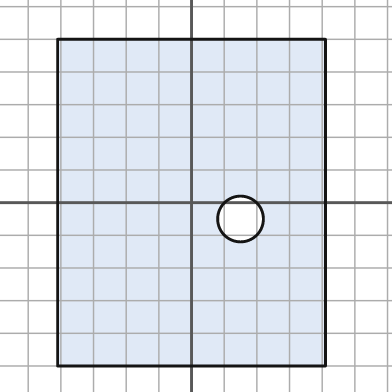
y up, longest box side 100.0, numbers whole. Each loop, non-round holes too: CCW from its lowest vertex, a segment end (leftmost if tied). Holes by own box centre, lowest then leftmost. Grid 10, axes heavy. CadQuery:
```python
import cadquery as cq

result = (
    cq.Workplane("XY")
    .moveTo(-41.0, -50.0)
    .lineTo(41.0, -50.0)
    .lineTo(41.0, 50.0)
    .lineTo(-41.0, 50.0)
    .close()
    .moveTo(15.0, -5.0)
    .circle(7.0)
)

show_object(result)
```